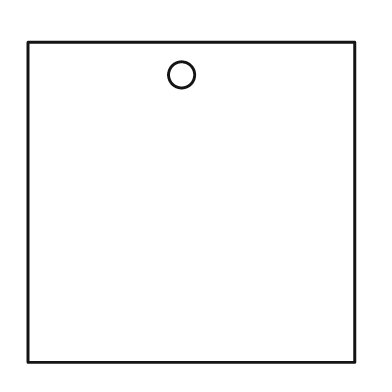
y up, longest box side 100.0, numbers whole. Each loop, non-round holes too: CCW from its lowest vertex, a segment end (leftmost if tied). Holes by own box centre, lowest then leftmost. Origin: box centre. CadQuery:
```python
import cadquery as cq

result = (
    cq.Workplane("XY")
    .moveTo(-50.0, -49.0)
    .lineTo(50.0, -49.0)
    .lineTo(50.0, 49.0)
    .lineTo(-50.0, 49.0)
    .close()
    .moveTo(-3.0, 39.0)
    .circle(4.0)
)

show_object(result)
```